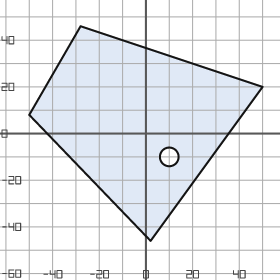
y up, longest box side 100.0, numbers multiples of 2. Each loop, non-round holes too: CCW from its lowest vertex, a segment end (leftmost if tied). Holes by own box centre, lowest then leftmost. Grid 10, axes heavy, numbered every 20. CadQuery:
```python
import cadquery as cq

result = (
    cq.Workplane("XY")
    .moveTo(2.0, -46.0)
    .lineTo(50.0, 20.0)
    .lineTo(-28.0, 46.0)
    .lineTo(-50.0, 8.0)
    .close()
    .moveTo(10.0, -10.0)
    .circle(4.0)
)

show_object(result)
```